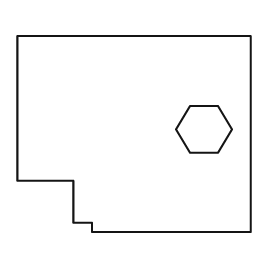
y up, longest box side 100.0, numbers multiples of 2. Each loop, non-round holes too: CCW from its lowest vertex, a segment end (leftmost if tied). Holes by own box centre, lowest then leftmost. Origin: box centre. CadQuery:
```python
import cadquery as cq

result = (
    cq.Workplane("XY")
    .moveTo(-18.0, -42.0)
    .lineTo(50.0, -42.0)
    .lineTo(50.0, 42.0)
    .lineTo(-50.0, 42.0)
    .lineTo(-50.0, -20.0)
    .lineTo(-26.0, -20.0)
    .lineTo(-26.0, -38.0)
    .lineTo(-18.0, -38.0)
    .close()
    .moveTo(24.0, -8.0)
    .lineTo(36.0, -8.0)
    .lineTo(42.0, 2.0)
    .lineTo(36.0, 12.0)
    .lineTo(24.0, 12.0)
    .lineTo(18.0, 2.0)
    .close()
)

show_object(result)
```